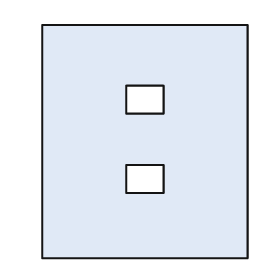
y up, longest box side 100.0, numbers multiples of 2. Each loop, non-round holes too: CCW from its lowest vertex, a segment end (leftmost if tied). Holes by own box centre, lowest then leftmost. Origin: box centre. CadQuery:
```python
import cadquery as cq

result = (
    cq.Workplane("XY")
    .moveTo(-44.0, -50.0)
    .lineTo(44.0, -50.0)
    .lineTo(44.0, 50.0)
    .lineTo(-44.0, 50.0)
    .close()
    .moveTo(-8.0, -22.0)
    .lineTo(8.0, -22.0)
    .lineTo(8.0, -10.0)
    .lineTo(-8.0, -10.0)
    .close()
    .moveTo(-8.0, 12.0)
    .lineTo(8.0, 12.0)
    .lineTo(8.0, 24.0)
    .lineTo(-8.0, 24.0)
    .close()
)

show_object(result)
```